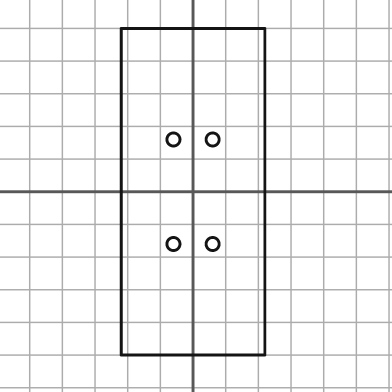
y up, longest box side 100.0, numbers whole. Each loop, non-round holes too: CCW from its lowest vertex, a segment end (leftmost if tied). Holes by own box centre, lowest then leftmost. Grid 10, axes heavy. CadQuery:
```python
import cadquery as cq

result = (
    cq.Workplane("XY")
    .moveTo(-22.0, -50.0)
    .lineTo(22.0, -50.0)
    .lineTo(22.0, 50.0)
    .lineTo(-22.0, 50.0)
    .close()
    .moveTo(-6.0, -16.0)
    .circle(2.0)
    .moveTo(6.0, -16.0)
    .circle(2.0)
    .moveTo(-6.0, 16.0)
    .circle(2.0)
    .moveTo(6.0, 16.0)
    .circle(2.0)
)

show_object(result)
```